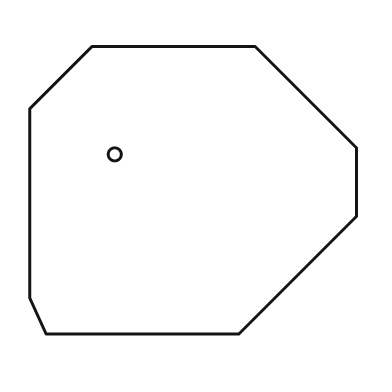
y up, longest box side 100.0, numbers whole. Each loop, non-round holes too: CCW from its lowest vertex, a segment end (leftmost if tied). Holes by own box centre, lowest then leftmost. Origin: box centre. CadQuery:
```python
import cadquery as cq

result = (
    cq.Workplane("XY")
    .moveTo(-45.0, -44.0)
    .lineTo(14.0, -44.0)
    .lineTo(50.0, -8.0)
    .lineTo(50.0, 13.0)
    .lineTo(19.0, 44.0)
    .lineTo(-31.0, 44.0)
    .lineTo(-50.0, 25.0)
    .lineTo(-50.0, -33.0)
    .close()
    .moveTo(-24.0, 11.0)
    .circle(2.0)
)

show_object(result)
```